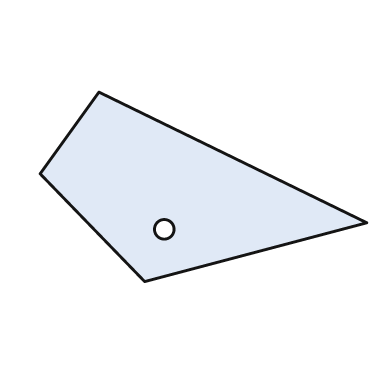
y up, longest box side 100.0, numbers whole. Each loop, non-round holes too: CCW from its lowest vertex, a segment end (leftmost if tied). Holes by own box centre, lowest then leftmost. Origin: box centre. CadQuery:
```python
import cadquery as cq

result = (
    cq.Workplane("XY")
    .moveTo(-18.0, -29.0)
    .lineTo(50.0, -11.0)
    .lineTo(-32.0, 29.0)
    .lineTo(-50.0, 4.0)
    .close()
    .moveTo(-12.0, -13.0)
    .circle(3.0)
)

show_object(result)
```